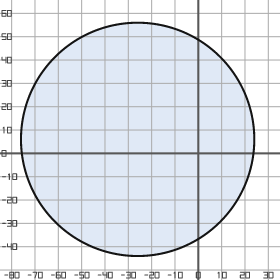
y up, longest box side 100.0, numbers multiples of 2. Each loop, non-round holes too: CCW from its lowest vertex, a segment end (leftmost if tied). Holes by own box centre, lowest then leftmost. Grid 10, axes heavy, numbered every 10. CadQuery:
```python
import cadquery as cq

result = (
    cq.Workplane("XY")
    .moveTo(-26.0, 6.0)
    .circle(50.0)
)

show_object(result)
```